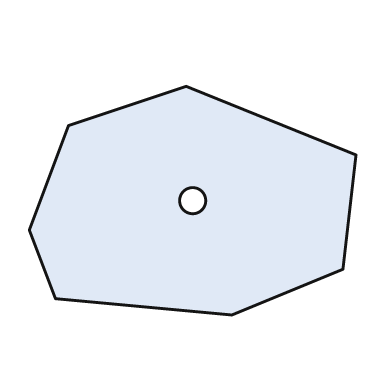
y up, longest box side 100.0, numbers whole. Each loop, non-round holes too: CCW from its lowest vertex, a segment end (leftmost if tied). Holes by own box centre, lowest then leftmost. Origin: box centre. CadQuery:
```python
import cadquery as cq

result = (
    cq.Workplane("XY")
    .moveTo(12.0, -35.0)
    .lineTo(46.0, -21.0)
    .lineTo(50.0, 14.0)
    .lineTo(-2.0, 35.0)
    .lineTo(-38.0, 23.0)
    .lineTo(-50.0, -9.0)
    .lineTo(-42.0, -30.0)
    .close()
    .moveTo(0.0, 0.0)
    .circle(4.0)
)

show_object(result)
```